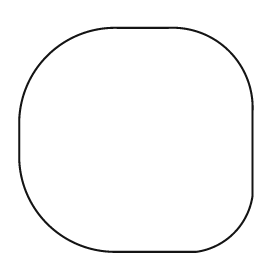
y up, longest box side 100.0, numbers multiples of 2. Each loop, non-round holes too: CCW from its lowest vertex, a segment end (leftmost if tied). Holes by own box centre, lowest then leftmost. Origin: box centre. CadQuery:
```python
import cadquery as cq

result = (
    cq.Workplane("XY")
    .moveTo(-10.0, -48.0)
    .lineTo(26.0, -48.0)
    .threePointArc((42.0, -40.0), (50.0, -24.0))
    .lineTo(50.0, 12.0)
    .threePointArc((40.0, 38.0), (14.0, 48.0))
    .lineTo(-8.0, 48.0)
    .threePointArc((-38.0, 36.0), (-50.0, 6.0))
    .lineTo(-50.0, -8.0)
    .threePointArc((-38.0, -36.0), (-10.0, -48.0))
    .close()
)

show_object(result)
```